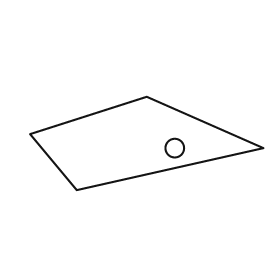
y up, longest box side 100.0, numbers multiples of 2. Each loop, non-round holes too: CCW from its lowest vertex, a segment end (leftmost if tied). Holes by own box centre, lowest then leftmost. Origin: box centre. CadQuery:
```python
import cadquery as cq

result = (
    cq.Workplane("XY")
    .moveTo(-30.0, -20.0)
    .lineTo(50.0, -2.0)
    .lineTo(0.0, 20.0)
    .lineTo(-50.0, 4.0)
    .close()
    .moveTo(12.0, -2.0)
    .circle(4.0)
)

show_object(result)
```